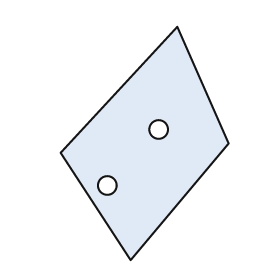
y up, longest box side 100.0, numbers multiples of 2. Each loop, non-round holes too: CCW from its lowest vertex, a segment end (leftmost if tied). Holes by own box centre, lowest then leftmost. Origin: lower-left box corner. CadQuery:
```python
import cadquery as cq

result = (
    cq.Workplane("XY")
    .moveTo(30.0, 0.0)
    .lineTo(72.0, 50.0)
    .lineTo(50.0, 100.0)
    .lineTo(0.0, 46.0)
    .close()
    .moveTo(20.0, 32.0)
    .circle(4.0)
    .moveTo(42.0, 56.0)
    .circle(4.0)
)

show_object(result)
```